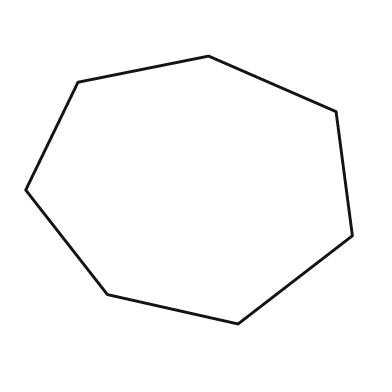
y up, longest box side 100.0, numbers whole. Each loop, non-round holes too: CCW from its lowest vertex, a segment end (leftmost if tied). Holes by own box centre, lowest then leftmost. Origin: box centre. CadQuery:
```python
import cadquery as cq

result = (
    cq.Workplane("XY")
    .moveTo(15.0, -41.0)
    .lineTo(50.0, -14.0)
    .lineTo(45.0, 24.0)
    .lineTo(6.0, 41.0)
    .lineTo(-34.0, 33.0)
    .lineTo(-50.0, 0.0)
    .lineTo(-25.0, -32.0)
    .close()
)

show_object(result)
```